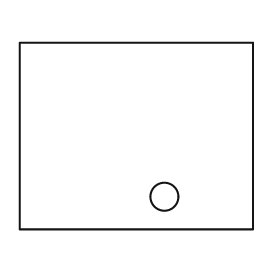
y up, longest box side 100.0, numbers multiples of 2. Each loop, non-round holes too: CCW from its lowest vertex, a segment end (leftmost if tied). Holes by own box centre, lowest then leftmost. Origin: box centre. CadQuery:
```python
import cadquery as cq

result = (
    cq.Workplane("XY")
    .moveTo(-50.0, -40.0)
    .lineTo(50.0, -40.0)
    .lineTo(50.0, 40.0)
    .lineTo(-50.0, 40.0)
    .close()
    .moveTo(12.0, -26.0)
    .circle(6.0)
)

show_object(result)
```